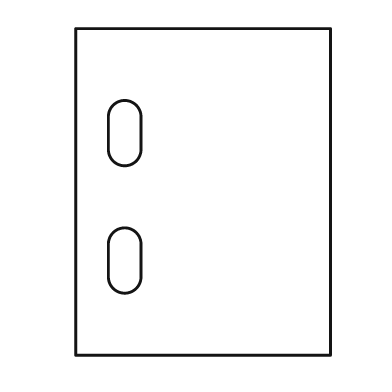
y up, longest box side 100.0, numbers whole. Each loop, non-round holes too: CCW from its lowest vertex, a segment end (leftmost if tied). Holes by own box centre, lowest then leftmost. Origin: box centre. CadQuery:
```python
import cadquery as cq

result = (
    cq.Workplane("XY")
    .moveTo(-39.0, -50.0)
    .lineTo(39.0, -50.0)
    .lineTo(39.0, 50.0)
    .lineTo(-39.0, 50.0)
    .close()
    .moveTo(-29.0, -26.0)
    .threePointArc((-24.0, -31.0), (-19.0, -26.0))
    .lineTo(-19.0, -16.0)
    .threePointArc((-24.0, -11.0), (-29.0, -16.0))
    .close()
    .moveTo(-29.0, 13.0)
    .threePointArc((-24.0, 8.0), (-19.0, 13.0))
    .lineTo(-19.0, 23.0)
    .threePointArc((-24.0, 28.0), (-29.0, 23.0))
    .close()
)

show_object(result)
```